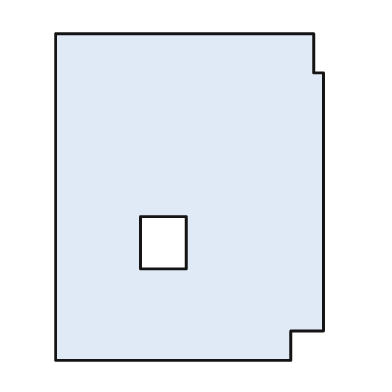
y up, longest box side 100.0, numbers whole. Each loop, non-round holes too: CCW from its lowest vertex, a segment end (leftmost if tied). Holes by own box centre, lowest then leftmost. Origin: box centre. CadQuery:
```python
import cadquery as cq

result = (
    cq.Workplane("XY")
    .moveTo(-41.0, -50.0)
    .lineTo(31.0, -50.0)
    .lineTo(31.0, -41.0)
    .lineTo(41.0, -41.0)
    .lineTo(41.0, 38.0)
    .lineTo(38.0, 38.0)
    .lineTo(38.0, 50.0)
    .lineTo(-41.0, 50.0)
    .close()
    .moveTo(-15.0, -22.0)
    .lineTo(-1.0, -22.0)
    .lineTo(-1.0, -6.0)
    .lineTo(-15.0, -6.0)
    .close()
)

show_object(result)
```